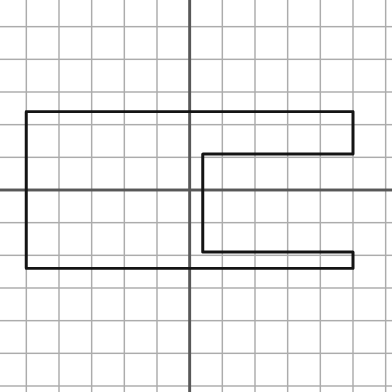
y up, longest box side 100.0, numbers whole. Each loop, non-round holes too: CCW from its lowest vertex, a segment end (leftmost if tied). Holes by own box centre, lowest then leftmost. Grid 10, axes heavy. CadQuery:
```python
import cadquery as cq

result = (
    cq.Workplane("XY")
    .moveTo(-50.0, -24.0)
    .lineTo(50.0, -24.0)
    .lineTo(50.0, -19.0)
    .lineTo(4.0, -19.0)
    .lineTo(4.0, 11.0)
    .lineTo(50.0, 11.0)
    .lineTo(50.0, 24.0)
    .lineTo(-50.0, 24.0)
    .close()
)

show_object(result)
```